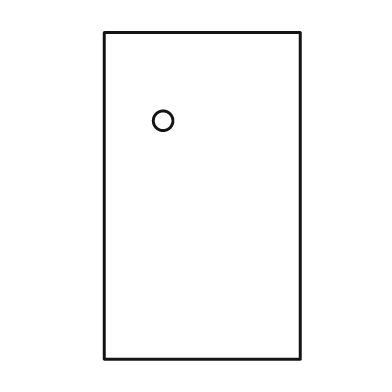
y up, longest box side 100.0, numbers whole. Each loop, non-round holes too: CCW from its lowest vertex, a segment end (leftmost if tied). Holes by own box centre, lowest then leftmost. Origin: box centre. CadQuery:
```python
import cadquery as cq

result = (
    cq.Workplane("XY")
    .moveTo(-30.0, -50.0)
    .lineTo(30.0, -50.0)
    .lineTo(30.0, 50.0)
    .lineTo(-30.0, 50.0)
    .close()
    .moveTo(-12.0, 23.0)
    .circle(3.0)
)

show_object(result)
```